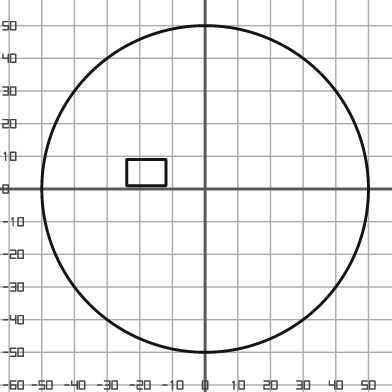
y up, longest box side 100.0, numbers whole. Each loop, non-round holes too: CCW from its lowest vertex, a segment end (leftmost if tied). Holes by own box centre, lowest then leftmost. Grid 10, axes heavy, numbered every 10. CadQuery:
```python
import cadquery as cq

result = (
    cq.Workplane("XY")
    .moveTo(0.0, 0.0)
    .circle(50.0)
    .moveTo(-24.0, 1.0)
    .lineTo(-12.0, 1.0)
    .lineTo(-12.0, 9.0)
    .lineTo(-24.0, 9.0)
    .close()
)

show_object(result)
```